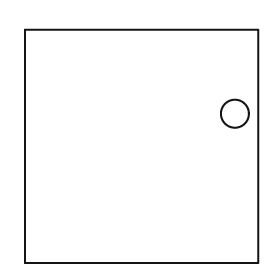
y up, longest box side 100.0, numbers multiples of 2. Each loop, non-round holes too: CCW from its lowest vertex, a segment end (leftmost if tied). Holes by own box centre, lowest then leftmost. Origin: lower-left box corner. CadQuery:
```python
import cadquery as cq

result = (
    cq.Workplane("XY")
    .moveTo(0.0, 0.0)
    .lineTo(100.0, 0.0)
    .lineTo(100.0, 100.0)
    .lineTo(0.0, 100.0)
    .close()
    .moveTo(90.0, 64.0)
    .circle(6.0)
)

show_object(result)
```